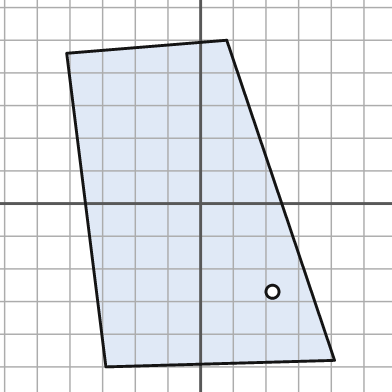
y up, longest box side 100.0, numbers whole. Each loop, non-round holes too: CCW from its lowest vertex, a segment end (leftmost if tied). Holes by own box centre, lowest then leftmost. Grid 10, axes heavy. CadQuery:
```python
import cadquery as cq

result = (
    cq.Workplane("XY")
    .moveTo(-29.0, -50.0)
    .lineTo(41.0, -48.0)
    .lineTo(8.0, 50.0)
    .lineTo(-41.0, 46.0)
    .close()
    .moveTo(22.0, -27.0)
    .circle(2.0)
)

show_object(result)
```